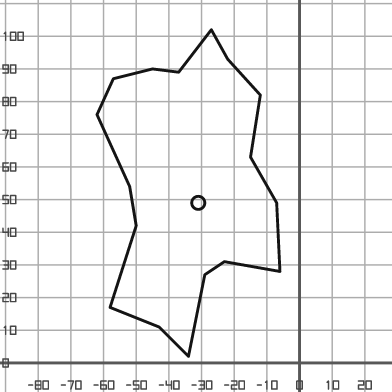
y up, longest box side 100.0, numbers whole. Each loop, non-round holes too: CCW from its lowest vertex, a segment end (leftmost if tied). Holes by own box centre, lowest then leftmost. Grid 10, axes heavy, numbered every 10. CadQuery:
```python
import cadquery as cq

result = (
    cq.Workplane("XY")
    .moveTo(-34.0, 2.0)
    .lineTo(-29.0, 27.0)
    .lineTo(-23.0, 31.0)
    .lineTo(-6.0, 28.0)
    .lineTo(-7.0, 49.0)
    .lineTo(-15.0, 63.0)
    .lineTo(-12.0, 82.0)
    .lineTo(-22.0, 93.0)
    .lineTo(-27.0, 102.0)
    .lineTo(-37.0, 89.0)
    .lineTo(-45.0, 90.0)
    .lineTo(-57.0, 87.0)
    .lineTo(-62.0, 76.0)
    .lineTo(-52.0, 54.0)
    .lineTo(-50.0, 42.0)
    .lineTo(-58.0, 17.0)
    .lineTo(-43.0, 11.0)
    .close()
    .moveTo(-31.0, 49.0)
    .circle(2.0)
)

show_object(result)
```